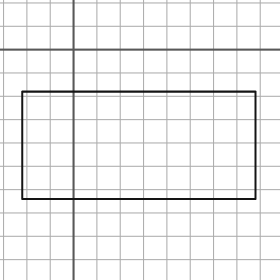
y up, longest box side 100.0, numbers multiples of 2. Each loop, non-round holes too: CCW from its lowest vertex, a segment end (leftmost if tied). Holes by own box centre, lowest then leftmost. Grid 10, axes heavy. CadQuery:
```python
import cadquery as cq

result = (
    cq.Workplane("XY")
    .moveTo(-22.0, -64.0)
    .lineTo(78.0, -64.0)
    .lineTo(78.0, -18.0)
    .lineTo(-22.0, -18.0)
    .close()
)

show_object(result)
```